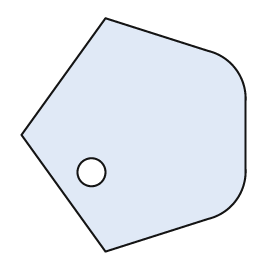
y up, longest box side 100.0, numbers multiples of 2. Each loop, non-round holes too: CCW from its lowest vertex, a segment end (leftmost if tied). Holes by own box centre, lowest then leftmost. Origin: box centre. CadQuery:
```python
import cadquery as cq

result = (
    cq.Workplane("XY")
    .moveTo(-12.0, -50.0)
    .lineTo(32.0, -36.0)
    .threePointArc((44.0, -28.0), (48.0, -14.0))
    .lineTo(48.0, 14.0)
    .threePointArc((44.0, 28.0), (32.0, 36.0))
    .lineTo(-12.0, 50.0)
    .lineTo(-48.0, 0.0)
    .close()
    .moveTo(-18.0, -16.0)
    .circle(6.0)
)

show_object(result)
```